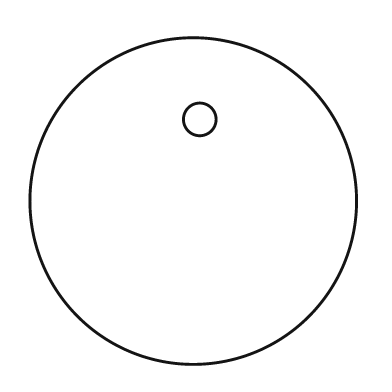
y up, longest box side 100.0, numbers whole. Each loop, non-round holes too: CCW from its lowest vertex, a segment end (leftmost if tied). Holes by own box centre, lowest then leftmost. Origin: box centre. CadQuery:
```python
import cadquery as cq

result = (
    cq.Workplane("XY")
    .moveTo(0.0, 0.0)
    .circle(50.0)
    .moveTo(2.0, 25.0)
    .circle(5.0)
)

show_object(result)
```